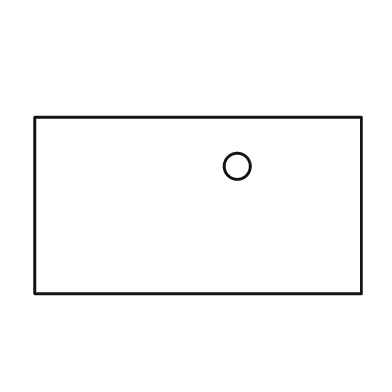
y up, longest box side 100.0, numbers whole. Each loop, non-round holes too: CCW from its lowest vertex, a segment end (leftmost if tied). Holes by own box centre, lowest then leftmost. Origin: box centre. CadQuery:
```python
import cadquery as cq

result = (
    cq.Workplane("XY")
    .moveTo(-50.0, -27.0)
    .lineTo(50.0, -27.0)
    .lineTo(50.0, 27.0)
    .lineTo(-50.0, 27.0)
    .close()
    .moveTo(12.0, 12.0)
    .circle(4.0)
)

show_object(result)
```